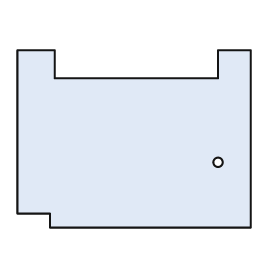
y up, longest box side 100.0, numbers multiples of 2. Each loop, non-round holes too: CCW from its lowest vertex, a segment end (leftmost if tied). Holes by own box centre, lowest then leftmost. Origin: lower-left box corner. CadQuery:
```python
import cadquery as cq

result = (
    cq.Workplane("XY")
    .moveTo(14.0, 0.0)
    .lineTo(100.0, 0.0)
    .lineTo(100.0, 76.0)
    .lineTo(86.0, 76.0)
    .lineTo(86.0, 64.0)
    .lineTo(16.0, 64.0)
    .lineTo(16.0, 76.0)
    .lineTo(0.0, 76.0)
    .lineTo(0.0, 6.0)
    .lineTo(14.0, 6.0)
    .close()
    .moveTo(86.0, 28.0)
    .circle(2.0)
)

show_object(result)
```